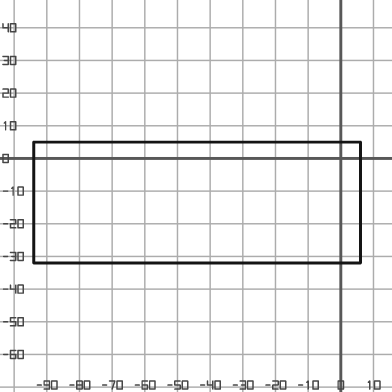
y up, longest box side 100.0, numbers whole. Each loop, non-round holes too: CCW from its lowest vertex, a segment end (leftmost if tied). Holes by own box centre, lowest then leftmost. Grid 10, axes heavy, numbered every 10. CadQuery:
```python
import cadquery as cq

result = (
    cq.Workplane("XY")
    .moveTo(-94.0, -32.0)
    .lineTo(6.0, -32.0)
    .lineTo(6.0, 5.0)
    .lineTo(-94.0, 5.0)
    .close()
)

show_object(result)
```